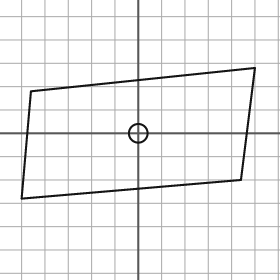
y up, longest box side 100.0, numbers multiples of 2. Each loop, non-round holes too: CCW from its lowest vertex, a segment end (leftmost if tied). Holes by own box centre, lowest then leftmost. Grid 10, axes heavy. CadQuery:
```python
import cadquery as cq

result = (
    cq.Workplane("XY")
    .moveTo(-50.0, -28.0)
    .lineTo(44.0, -20.0)
    .lineTo(50.0, 28.0)
    .lineTo(-46.0, 18.0)
    .close()
    .moveTo(0.0, 0.0)
    .circle(4.0)
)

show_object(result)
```